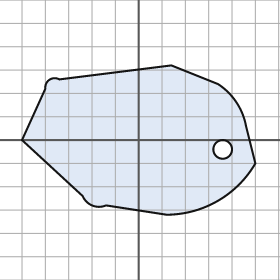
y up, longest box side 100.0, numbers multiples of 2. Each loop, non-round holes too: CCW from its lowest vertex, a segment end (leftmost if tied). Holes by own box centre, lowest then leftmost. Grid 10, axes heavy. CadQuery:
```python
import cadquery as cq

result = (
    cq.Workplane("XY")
    .moveTo(12.0, -32.0)
    .threePointArc((34.0, -26.0), (50.0, -10.0))
    .lineTo(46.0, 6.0)
    .threePointArc((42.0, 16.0), (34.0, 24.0))
    .lineTo(14.0, 32.0)
    .lineTo(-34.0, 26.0)
    .threePointArc((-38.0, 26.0), (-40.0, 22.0))
    .lineTo(-50.0, 0.0)
    .lineTo(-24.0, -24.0)
    .threePointArc((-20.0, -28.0), (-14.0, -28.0))
    .close()
    .moveTo(36.0, -4.0)
    .circle(4.0)
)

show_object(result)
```